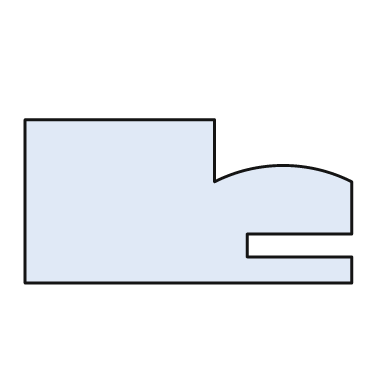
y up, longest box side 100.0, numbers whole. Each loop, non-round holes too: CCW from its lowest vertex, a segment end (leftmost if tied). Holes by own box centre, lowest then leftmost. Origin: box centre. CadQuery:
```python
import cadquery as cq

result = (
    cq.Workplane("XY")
    .moveTo(-50.0, -25.0)
    .lineTo(50.0, -25.0)
    .lineTo(50.0, -17.0)
    .lineTo(18.0, -17.0)
    .lineTo(18.0, -10.0)
    .lineTo(50.0, -10.0)
    .lineTo(50.0, 6.0)
    .threePointArc((29.0, 11.0), (8.0, 6.0))
    .lineTo(8.0, 25.0)
    .lineTo(-50.0, 25.0)
    .close()
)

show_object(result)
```